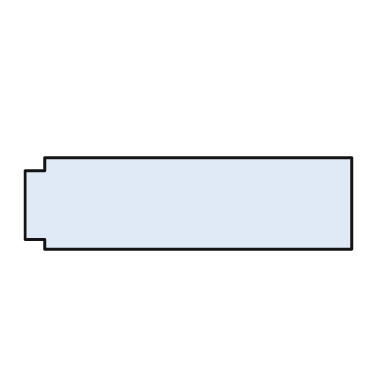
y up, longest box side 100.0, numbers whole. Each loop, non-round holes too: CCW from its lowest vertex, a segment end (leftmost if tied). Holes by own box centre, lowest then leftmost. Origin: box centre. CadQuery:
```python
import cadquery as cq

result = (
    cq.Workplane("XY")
    .moveTo(-44.0, -14.0)
    .lineTo(50.0, -14.0)
    .lineTo(50.0, 14.0)
    .lineTo(-44.0, 14.0)
    .lineTo(-44.0, 10.0)
    .lineTo(-50.0, 10.0)
    .lineTo(-50.0, -11.0)
    .lineTo(-44.0, -11.0)
    .close()
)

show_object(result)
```